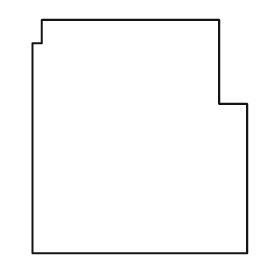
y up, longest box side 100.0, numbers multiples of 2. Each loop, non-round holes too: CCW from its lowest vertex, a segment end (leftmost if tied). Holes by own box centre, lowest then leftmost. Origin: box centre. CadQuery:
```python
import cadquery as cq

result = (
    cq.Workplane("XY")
    .moveTo(-46.0, -50.0)
    .lineTo(46.0, -50.0)
    .lineTo(46.0, 14.0)
    .lineTo(34.0, 14.0)
    .lineTo(34.0, 50.0)
    .lineTo(-42.0, 50.0)
    .lineTo(-42.0, 40.0)
    .lineTo(-46.0, 40.0)
    .close()
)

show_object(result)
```